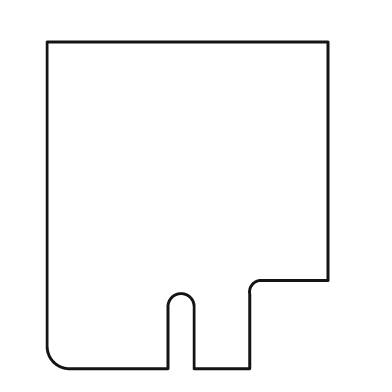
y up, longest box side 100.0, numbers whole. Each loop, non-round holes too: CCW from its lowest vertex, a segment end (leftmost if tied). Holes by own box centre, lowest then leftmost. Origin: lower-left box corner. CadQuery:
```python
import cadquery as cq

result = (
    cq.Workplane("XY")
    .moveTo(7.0, 0.0)
    .lineTo(37.0, 0.0)
    .lineTo(37.0, 19.0)
    .threePointArc((41.0, 23.0), (45.0, 19.0))
    .lineTo(45.0, 0.0)
    .lineTo(62.0, 0.0)
    .lineTo(62.0, 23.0)
    .threePointArc((63.0, 26.0), (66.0, 27.0))
    .lineTo(86.0, 27.0)
    .lineTo(86.0, 100.0)
    .lineTo(0.0, 100.0)
    .lineTo(0.0, 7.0)
    .threePointArc((2.0, 2.0), (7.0, 0.0))
    .close()
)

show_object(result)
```